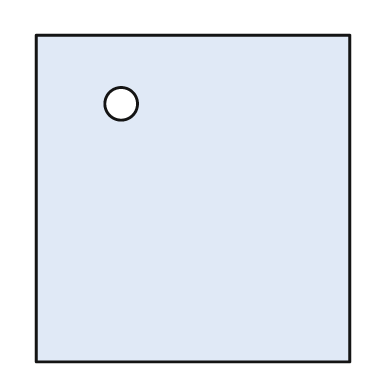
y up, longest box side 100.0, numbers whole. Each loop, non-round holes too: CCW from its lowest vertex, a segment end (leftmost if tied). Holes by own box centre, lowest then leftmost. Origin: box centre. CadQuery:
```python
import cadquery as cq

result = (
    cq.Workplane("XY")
    .moveTo(-48.0, -50.0)
    .lineTo(48.0, -50.0)
    .lineTo(48.0, 50.0)
    .lineTo(-48.0, 50.0)
    .close()
    .moveTo(-22.0, 29.0)
    .circle(5.0)
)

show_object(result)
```